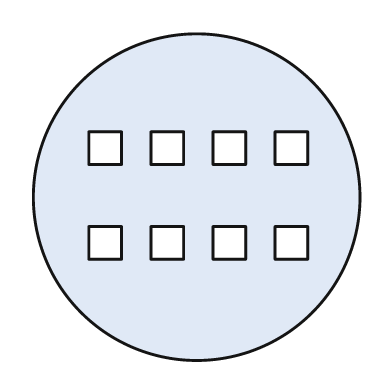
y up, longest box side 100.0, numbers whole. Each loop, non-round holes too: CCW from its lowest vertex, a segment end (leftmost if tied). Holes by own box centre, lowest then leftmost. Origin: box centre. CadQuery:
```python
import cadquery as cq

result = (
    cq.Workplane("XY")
    .moveTo(0.0, 0.0)
    .circle(50.0)
    .moveTo(-33.0, -19.0)
    .lineTo(-23.0, -19.0)
    .lineTo(-23.0, -9.0)
    .lineTo(-33.0, -9.0)
    .close()
    .moveTo(-14.0, -19.0)
    .lineTo(-4.0, -19.0)
    .lineTo(-4.0, -9.0)
    .lineTo(-14.0, -9.0)
    .close()
    .moveTo(5.0, -19.0)
    .lineTo(15.0, -19.0)
    .lineTo(15.0, -9.0)
    .lineTo(5.0, -9.0)
    .close()
    .moveTo(24.0, -19.0)
    .lineTo(34.0, -19.0)
    .lineTo(34.0, -9.0)
    .lineTo(24.0, -9.0)
    .close()
    .moveTo(-33.0, 10.0)
    .lineTo(-23.0, 10.0)
    .lineTo(-23.0, 20.0)
    .lineTo(-33.0, 20.0)
    .close()
    .moveTo(-14.0, 10.0)
    .lineTo(-4.0, 10.0)
    .lineTo(-4.0, 20.0)
    .lineTo(-14.0, 20.0)
    .close()
    .moveTo(5.0, 10.0)
    .lineTo(15.0, 10.0)
    .lineTo(15.0, 20.0)
    .lineTo(5.0, 20.0)
    .close()
    .moveTo(24.0, 10.0)
    .lineTo(34.0, 10.0)
    .lineTo(34.0, 20.0)
    .lineTo(24.0, 20.0)
    .close()
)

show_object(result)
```